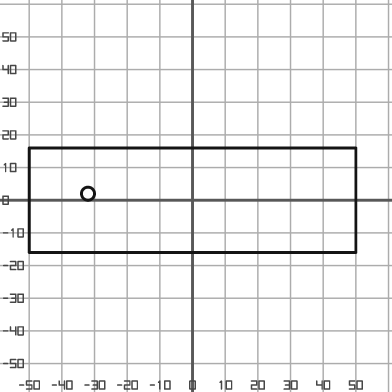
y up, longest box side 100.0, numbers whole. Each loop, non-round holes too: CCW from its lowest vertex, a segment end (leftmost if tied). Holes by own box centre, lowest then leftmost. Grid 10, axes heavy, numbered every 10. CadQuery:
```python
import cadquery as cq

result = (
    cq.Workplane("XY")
    .moveTo(-50.0, -16.0)
    .lineTo(50.0, -16.0)
    .lineTo(50.0, 16.0)
    .lineTo(-50.0, 16.0)
    .close()
    .moveTo(-32.0, 2.0)
    .circle(2.0)
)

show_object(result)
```